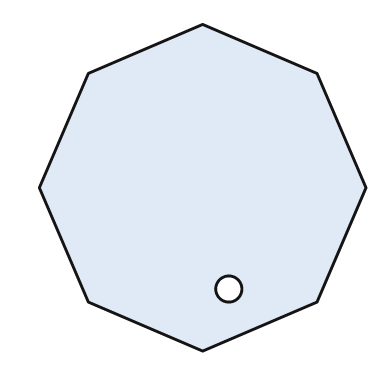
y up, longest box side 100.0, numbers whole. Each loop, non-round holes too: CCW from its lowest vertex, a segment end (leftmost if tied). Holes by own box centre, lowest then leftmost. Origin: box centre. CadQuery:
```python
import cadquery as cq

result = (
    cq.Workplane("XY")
    .moveTo(0.0, -50.0)
    .lineTo(35.0, -35.0)
    .lineTo(50.0, 0.0)
    .lineTo(35.0, 35.0)
    .lineTo(0.0, 50.0)
    .lineTo(-35.0, 35.0)
    .lineTo(-50.0, 0.0)
    .lineTo(-35.0, -35.0)
    .close()
    .moveTo(8.0, -31.0)
    .circle(4.0)
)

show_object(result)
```